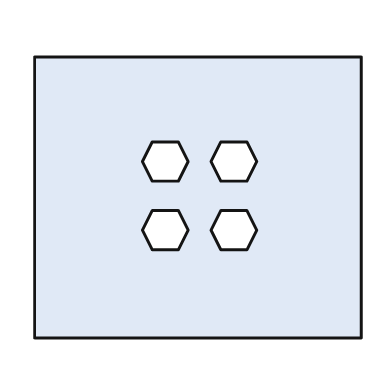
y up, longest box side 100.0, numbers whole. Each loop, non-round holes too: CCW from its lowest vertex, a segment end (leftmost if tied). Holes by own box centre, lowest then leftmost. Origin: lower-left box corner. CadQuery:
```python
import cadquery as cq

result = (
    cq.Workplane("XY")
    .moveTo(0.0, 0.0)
    .lineTo(100.0, 0.0)
    .lineTo(100.0, 86.0)
    .lineTo(0.0, 86.0)
    .close()
    .moveTo(36.0, 27.0)
    .lineTo(44.0, 27.0)
    .lineTo(47.0, 33.0)
    .lineTo(44.0, 39.0)
    .lineTo(36.0, 39.0)
    .lineTo(33.0, 33.0)
    .close()
    .moveTo(57.0, 27.0)
    .lineTo(65.0, 27.0)
    .lineTo(68.0, 33.0)
    .lineTo(65.0, 39.0)
    .lineTo(57.0, 39.0)
    .lineTo(54.0, 33.0)
    .close()
    .moveTo(36.0, 48.0)
    .lineTo(44.0, 48.0)
    .lineTo(47.0, 54.0)
    .lineTo(44.0, 60.0)
    .lineTo(36.0, 60.0)
    .lineTo(33.0, 54.0)
    .close()
    .moveTo(57.0, 48.0)
    .lineTo(65.0, 48.0)
    .lineTo(68.0, 54.0)
    .lineTo(65.0, 60.0)
    .lineTo(57.0, 60.0)
    .lineTo(54.0, 54.0)
    .close()
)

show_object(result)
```